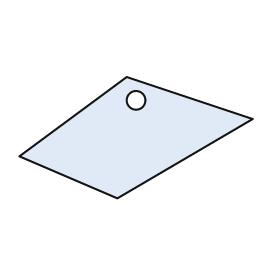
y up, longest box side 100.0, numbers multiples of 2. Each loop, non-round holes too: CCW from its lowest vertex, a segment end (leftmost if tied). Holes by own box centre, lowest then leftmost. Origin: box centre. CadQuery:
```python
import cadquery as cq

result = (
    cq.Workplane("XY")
    .moveTo(-8.0, -26.0)
    .lineTo(50.0, 8.0)
    .lineTo(-4.0, 26.0)
    .lineTo(-50.0, -8.0)
    .close()
    .moveTo(0.0, 16.0)
    .circle(4.0)
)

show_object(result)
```